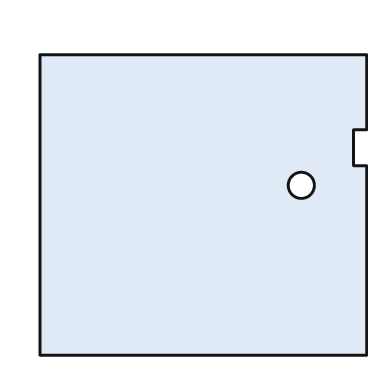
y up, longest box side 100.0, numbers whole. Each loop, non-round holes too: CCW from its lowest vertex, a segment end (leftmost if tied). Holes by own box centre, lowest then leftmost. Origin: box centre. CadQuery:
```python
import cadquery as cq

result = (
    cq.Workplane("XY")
    .moveTo(-50.0, -46.0)
    .lineTo(50.0, -46.0)
    .lineTo(50.0, 12.0)
    .lineTo(46.0, 12.0)
    .lineTo(46.0, 23.0)
    .lineTo(50.0, 23.0)
    .lineTo(50.0, 46.0)
    .lineTo(-50.0, 46.0)
    .close()
    .moveTo(30.0, 6.0)
    .circle(4.0)
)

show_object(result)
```